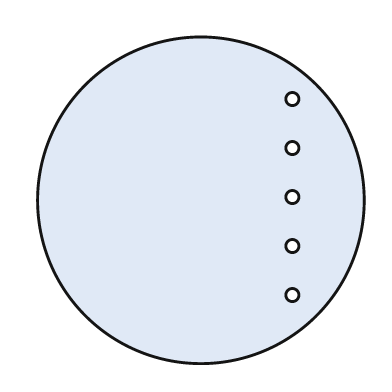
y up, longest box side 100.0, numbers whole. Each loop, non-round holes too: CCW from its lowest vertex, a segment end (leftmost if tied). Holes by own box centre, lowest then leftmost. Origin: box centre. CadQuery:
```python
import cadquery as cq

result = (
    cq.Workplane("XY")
    .moveTo(0.0, 0.0)
    .circle(50.0)
    .moveTo(28.0, -29.0)
    .circle(2.0)
    .moveTo(28.0, -14.0)
    .circle(2.0)
    .moveTo(28.0, 1.0)
    .circle(2.0)
    .moveTo(28.0, 16.0)
    .circle(2.0)
    .moveTo(28.0, 31.0)
    .circle(2.0)
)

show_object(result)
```